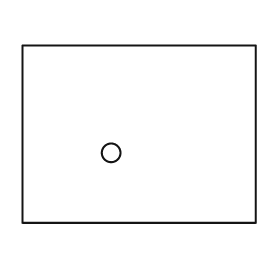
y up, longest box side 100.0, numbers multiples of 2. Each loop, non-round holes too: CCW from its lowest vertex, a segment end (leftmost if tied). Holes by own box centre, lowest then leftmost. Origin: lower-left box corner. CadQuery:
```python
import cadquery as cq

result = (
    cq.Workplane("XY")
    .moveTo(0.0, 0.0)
    .lineTo(100.0, 0.0)
    .lineTo(100.0, 76.0)
    .lineTo(0.0, 76.0)
    .close()
    .moveTo(38.0, 30.0)
    .circle(4.0)
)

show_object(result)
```